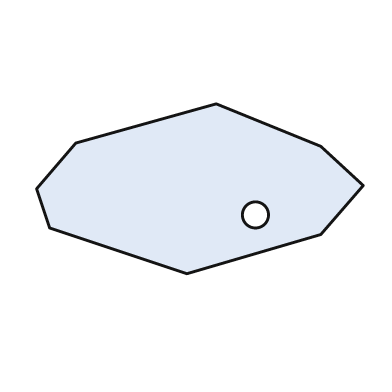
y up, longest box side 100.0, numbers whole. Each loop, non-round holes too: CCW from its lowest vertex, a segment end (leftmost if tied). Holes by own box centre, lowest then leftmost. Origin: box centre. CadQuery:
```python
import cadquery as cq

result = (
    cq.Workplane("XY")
    .moveTo(-4.0, -26.0)
    .lineTo(37.0, -14.0)
    .lineTo(50.0, 1.0)
    .lineTo(37.0, 13.0)
    .lineTo(5.0, 26.0)
    .lineTo(-38.0, 14.0)
    .lineTo(-50.0, 0.0)
    .lineTo(-46.0, -12.0)
    .close()
    .moveTo(17.0, -8.0)
    .circle(4.0)
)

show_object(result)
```